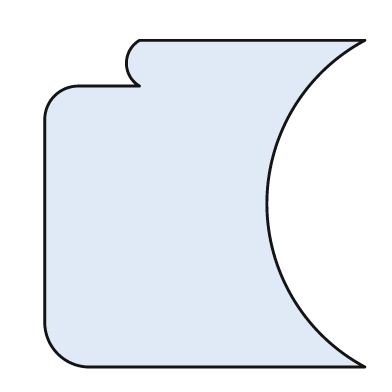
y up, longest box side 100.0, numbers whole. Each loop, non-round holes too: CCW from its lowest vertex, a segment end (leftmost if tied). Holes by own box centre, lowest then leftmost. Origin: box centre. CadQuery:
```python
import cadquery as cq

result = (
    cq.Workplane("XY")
    .moveTo(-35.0, -50.0)
    .lineTo(49.0, -50.0)
    .threePointArc((19.0, 0.0), (49.0, 50.0))
    .lineTo(-20.0, 50.0)
    .threePointArc((-24.0, 43.0), (-20.0, 36.0))
    .lineTo(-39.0, 36.0)
    .threePointArc((-46.0, 33.0), (-49.0, 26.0))
    .lineTo(-49.0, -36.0)
    .threePointArc((-45.0, -46.0), (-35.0, -50.0))
    .close()
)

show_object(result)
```